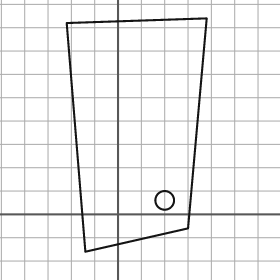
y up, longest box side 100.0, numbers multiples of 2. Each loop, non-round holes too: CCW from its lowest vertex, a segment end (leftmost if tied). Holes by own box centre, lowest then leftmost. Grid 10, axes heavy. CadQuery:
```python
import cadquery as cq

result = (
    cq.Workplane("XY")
    .moveTo(-14.0, -16.0)
    .lineTo(30.0, -6.0)
    .lineTo(38.0, 84.0)
    .lineTo(-22.0, 82.0)
    .close()
    .moveTo(20.0, 6.0)
    .circle(4.0)
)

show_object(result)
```